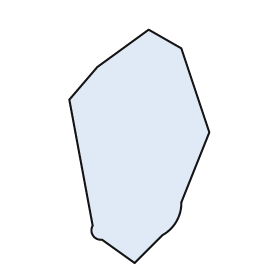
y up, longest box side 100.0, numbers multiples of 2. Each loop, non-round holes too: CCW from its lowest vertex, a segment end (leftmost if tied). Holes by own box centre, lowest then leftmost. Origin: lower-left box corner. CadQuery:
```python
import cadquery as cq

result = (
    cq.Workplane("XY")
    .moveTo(28.0, 0.0)
    .lineTo(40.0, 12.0)
    .threePointArc((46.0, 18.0), (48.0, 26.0))
    .lineTo(60.0, 56.0)
    .lineTo(48.0, 92.0)
    .lineTo(34.0, 100.0)
    .lineTo(12.0, 84.0)
    .lineTo(0.0, 70.0)
    .lineTo(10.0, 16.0)
    .threePointArc((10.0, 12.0), (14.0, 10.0))
    .close()
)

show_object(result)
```